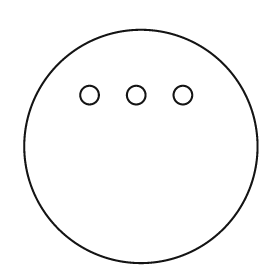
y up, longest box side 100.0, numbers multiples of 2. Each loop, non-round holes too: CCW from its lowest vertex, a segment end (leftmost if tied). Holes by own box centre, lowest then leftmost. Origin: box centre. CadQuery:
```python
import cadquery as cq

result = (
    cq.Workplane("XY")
    .moveTo(0.0, 0.0)
    .circle(50.0)
    .moveTo(-22.0, 22.0)
    .circle(4.0)
    .moveTo(-2.0, 22.0)
    .circle(4.0)
    .moveTo(18.0, 22.0)
    .circle(4.0)
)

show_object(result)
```